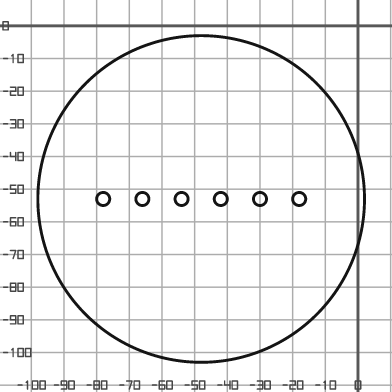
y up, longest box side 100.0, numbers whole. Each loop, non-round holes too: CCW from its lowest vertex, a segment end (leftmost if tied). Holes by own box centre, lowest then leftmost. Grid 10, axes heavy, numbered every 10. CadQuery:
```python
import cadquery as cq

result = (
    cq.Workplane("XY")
    .moveTo(-48.0, -53.0)
    .circle(50.0)
    .moveTo(-78.0, -53.0)
    .circle(2.0)
    .moveTo(-66.0, -53.0)
    .circle(2.0)
    .moveTo(-54.0, -53.0)
    .circle(2.0)
    .moveTo(-42.0, -53.0)
    .circle(2.0)
    .moveTo(-30.0, -53.0)
    .circle(2.0)
    .moveTo(-18.0, -53.0)
    .circle(2.0)
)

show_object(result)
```